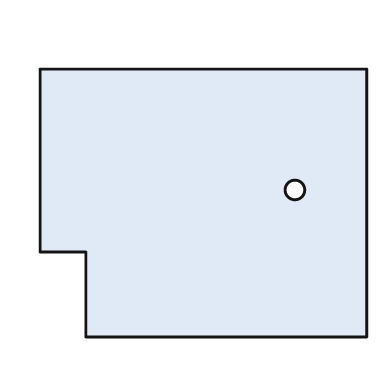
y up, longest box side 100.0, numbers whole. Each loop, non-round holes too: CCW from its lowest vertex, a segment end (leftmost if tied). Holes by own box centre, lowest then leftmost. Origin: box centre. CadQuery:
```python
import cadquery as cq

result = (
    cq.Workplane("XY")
    .moveTo(-36.0, -41.0)
    .lineTo(50.0, -41.0)
    .lineTo(50.0, 41.0)
    .lineTo(-50.0, 41.0)
    .lineTo(-50.0, -15.0)
    .lineTo(-36.0, -15.0)
    .close()
    .moveTo(28.0, 4.0)
    .circle(3.0)
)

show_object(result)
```